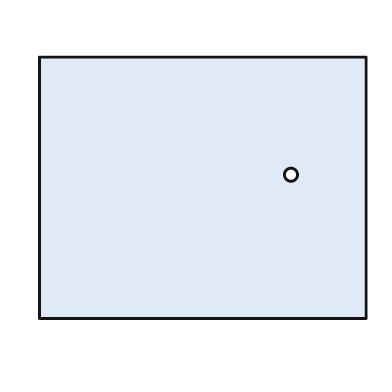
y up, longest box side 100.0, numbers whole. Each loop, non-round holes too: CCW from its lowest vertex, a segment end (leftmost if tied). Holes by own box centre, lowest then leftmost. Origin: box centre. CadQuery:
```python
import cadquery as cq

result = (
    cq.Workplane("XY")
    .moveTo(-50.0, -40.0)
    .lineTo(50.0, -40.0)
    .lineTo(50.0, 40.0)
    .lineTo(-50.0, 40.0)
    .close()
    .moveTo(27.0, 4.0)
    .circle(2.0)
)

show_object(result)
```